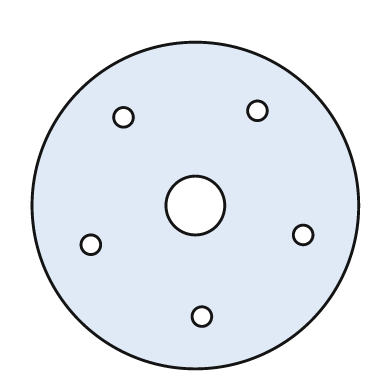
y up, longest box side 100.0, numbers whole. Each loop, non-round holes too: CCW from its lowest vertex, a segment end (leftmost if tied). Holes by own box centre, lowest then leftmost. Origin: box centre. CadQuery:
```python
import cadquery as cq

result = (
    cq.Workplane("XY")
    .moveTo(0.0, 0.0)
    .circle(50.0)
    .moveTo(2.0, -34.0)
    .circle(3.0)
    .moveTo(-32.0, -12.0)
    .circle(3.0)
    .moveTo(33.0, -9.0)
    .circle(3.0)
    .moveTo(0.0, 0.0)
    .circle(9.0)
    .moveTo(-22.0, 27.0)
    .circle(3.0)
    .moveTo(19.0, 29.0)
    .circle(3.0)
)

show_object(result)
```